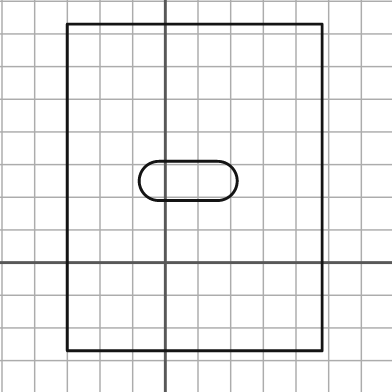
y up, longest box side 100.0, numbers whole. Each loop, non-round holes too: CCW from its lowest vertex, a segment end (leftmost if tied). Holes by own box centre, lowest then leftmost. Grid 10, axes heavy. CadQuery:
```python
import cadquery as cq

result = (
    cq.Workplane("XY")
    .moveTo(-30.0, -27.0)
    .lineTo(48.0, -27.0)
    .lineTo(48.0, 73.0)
    .lineTo(-30.0, 73.0)
    .close()
    .moveTo(-2.0, 19.0)
    .lineTo(16.0, 19.0)
    .threePointArc((22.0, 25.0), (16.0, 31.0))
    .lineTo(-2.0, 31.0)
    .threePointArc((-8.0, 25.0), (-2.0, 19.0))
    .close()
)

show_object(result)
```